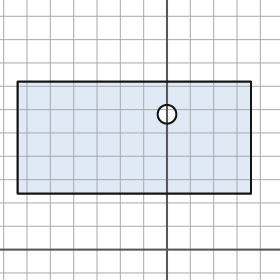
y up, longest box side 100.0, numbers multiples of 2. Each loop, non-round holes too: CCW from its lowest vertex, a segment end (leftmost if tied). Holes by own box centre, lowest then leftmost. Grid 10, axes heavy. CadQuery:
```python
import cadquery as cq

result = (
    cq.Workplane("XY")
    .moveTo(-64.0, 24.0)
    .lineTo(36.0, 24.0)
    .lineTo(36.0, 72.0)
    .lineTo(-64.0, 72.0)
    .close()
    .moveTo(0.0, 58.0)
    .circle(4.0)
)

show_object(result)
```